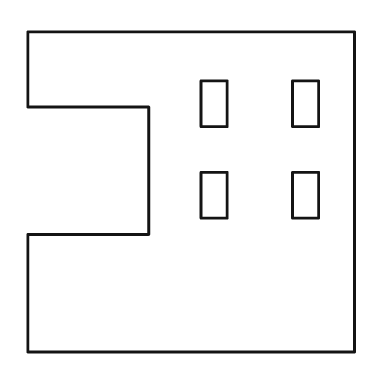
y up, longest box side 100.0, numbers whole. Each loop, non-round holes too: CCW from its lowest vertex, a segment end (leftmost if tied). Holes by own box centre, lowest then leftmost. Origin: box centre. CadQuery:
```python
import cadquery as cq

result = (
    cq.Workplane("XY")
    .moveTo(-50.0, -49.0)
    .lineTo(50.0, -49.0)
    .lineTo(50.0, 49.0)
    .lineTo(-50.0, 49.0)
    .lineTo(-50.0, 26.0)
    .lineTo(-13.0, 26.0)
    .lineTo(-13.0, -13.0)
    .lineTo(-50.0, -13.0)
    .close()
    .moveTo(3.0, -8.0)
    .lineTo(11.0, -8.0)
    .lineTo(11.0, 6.0)
    .lineTo(3.0, 6.0)
    .close()
    .moveTo(31.0, -8.0)
    .lineTo(39.0, -8.0)
    .lineTo(39.0, 6.0)
    .lineTo(31.0, 6.0)
    .close()
    .moveTo(3.0, 20.0)
    .lineTo(11.0, 20.0)
    .lineTo(11.0, 34.0)
    .lineTo(3.0, 34.0)
    .close()
    .moveTo(31.0, 20.0)
    .lineTo(39.0, 20.0)
    .lineTo(39.0, 34.0)
    .lineTo(31.0, 34.0)
    .close()
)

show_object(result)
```